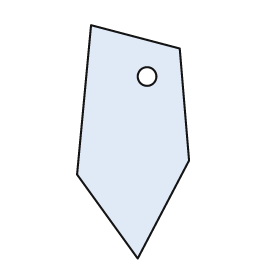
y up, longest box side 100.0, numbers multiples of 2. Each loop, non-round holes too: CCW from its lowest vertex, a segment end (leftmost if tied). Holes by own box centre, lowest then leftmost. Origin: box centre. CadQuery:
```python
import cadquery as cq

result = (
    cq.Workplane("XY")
    .moveTo(2.0, -50.0)
    .lineTo(24.0, -8.0)
    .lineTo(20.0, 40.0)
    .lineTo(-18.0, 50.0)
    .lineTo(-24.0, -14.0)
    .close()
    .moveTo(6.0, 28.0)
    .circle(4.0)
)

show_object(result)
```